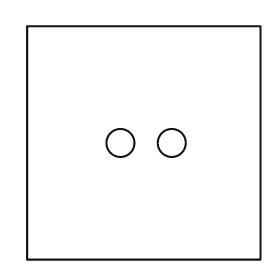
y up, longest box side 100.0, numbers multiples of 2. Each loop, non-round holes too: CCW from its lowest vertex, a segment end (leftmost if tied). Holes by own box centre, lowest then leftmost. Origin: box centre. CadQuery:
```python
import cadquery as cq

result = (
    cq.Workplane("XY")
    .moveTo(-50.0, -50.0)
    .lineTo(50.0, -50.0)
    .lineTo(50.0, 50.0)
    .lineTo(-50.0, 50.0)
    .close()
    .moveTo(-10.0, 0.0)
    .circle(6.0)
    .moveTo(12.0, 0.0)
    .circle(6.0)
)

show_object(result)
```